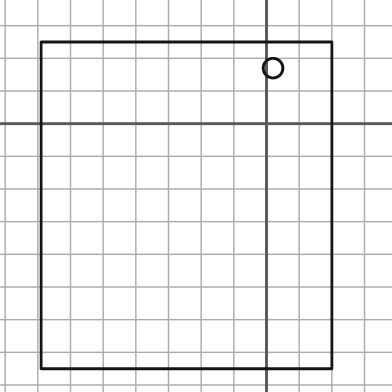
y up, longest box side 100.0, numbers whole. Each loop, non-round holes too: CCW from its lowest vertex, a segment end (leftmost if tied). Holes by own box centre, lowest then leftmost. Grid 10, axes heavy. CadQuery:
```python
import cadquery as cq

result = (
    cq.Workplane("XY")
    .moveTo(-69.0, -75.0)
    .lineTo(20.0, -75.0)
    .lineTo(20.0, 25.0)
    .lineTo(-69.0, 25.0)
    .close()
    .moveTo(2.0, 17.0)
    .circle(3.0)
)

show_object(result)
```